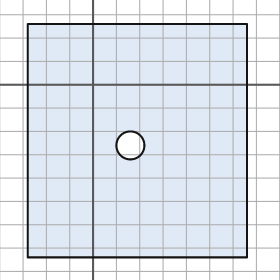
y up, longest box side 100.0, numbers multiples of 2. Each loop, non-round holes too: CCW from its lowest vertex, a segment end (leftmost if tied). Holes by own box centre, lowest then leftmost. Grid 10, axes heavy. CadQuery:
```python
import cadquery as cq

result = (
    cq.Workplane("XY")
    .moveTo(-28.0, -74.0)
    .lineTo(66.0, -74.0)
    .lineTo(66.0, 26.0)
    .lineTo(-28.0, 26.0)
    .close()
    .moveTo(16.0, -26.0)
    .circle(6.0)
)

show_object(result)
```